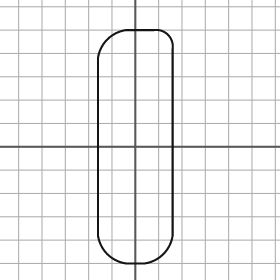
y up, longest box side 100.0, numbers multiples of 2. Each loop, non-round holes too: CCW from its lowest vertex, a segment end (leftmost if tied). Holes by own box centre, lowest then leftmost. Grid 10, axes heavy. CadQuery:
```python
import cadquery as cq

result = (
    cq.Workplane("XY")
    .moveTo(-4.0, -50.0)
    .lineTo(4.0, -50.0)
    .threePointArc((12.0, -46.0), (16.0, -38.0))
    .lineTo(16.0, 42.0)
    .threePointArc((14.0, 48.0), (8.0, 50.0))
    .lineTo(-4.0, 50.0)
    .threePointArc((-12.0, 46.0), (-16.0, 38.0))
    .lineTo(-16.0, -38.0)
    .threePointArc((-12.0, -46.0), (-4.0, -50.0))
    .close()
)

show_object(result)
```